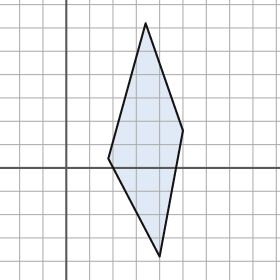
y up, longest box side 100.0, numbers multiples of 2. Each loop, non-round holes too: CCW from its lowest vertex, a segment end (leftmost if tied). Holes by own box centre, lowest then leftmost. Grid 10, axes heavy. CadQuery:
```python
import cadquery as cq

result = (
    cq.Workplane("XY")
    .moveTo(40.0, -38.0)
    .lineTo(50.0, 16.0)
    .lineTo(34.0, 62.0)
    .lineTo(18.0, 4.0)
    .close()
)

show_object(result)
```